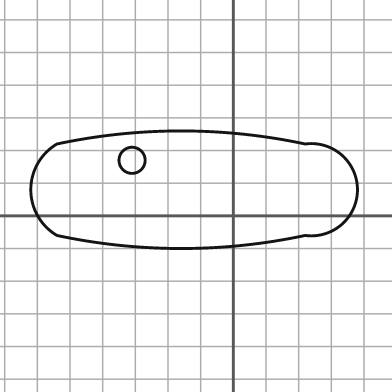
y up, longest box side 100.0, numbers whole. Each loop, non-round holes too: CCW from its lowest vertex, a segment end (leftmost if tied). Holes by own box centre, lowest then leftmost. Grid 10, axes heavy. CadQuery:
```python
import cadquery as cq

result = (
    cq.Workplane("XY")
    .moveTo(-54.0, -6.0)
    .threePointArc((-16.0, -10.0), (22.0, -6.0))
    .threePointArc((38.0, 8.0), (22.0, 22.0))
    .threePointArc((-16.0, 26.0), (-54.0, 22.0))
    .threePointArc((-62.0, 8.0), (-54.0, -6.0))
    .close()
    .moveTo(-31.0, 17.0)
    .circle(4.0)
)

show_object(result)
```